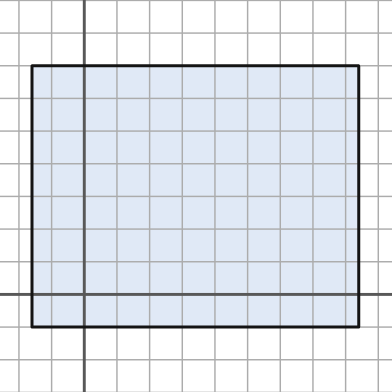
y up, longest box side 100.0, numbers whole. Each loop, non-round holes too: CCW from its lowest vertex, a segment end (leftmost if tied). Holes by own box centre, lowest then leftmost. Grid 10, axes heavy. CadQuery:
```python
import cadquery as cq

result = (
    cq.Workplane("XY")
    .moveTo(-16.0, -10.0)
    .lineTo(84.0, -10.0)
    .lineTo(84.0, 70.0)
    .lineTo(-16.0, 70.0)
    .close()
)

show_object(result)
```